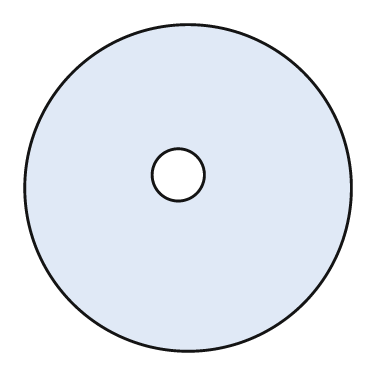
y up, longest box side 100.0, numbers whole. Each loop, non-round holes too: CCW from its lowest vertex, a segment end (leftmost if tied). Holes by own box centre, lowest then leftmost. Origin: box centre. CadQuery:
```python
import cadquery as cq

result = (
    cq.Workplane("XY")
    .moveTo(0.0, 0.0)
    .circle(50.0)
    .moveTo(-3.0, 4.0)
    .circle(8.0)
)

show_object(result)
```